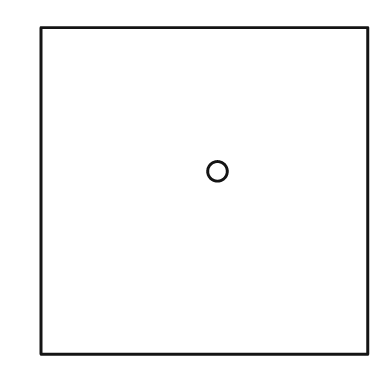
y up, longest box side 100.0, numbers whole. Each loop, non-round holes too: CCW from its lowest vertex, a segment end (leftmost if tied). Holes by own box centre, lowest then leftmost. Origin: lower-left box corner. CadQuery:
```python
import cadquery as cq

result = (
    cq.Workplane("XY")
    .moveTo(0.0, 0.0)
    .lineTo(100.0, 0.0)
    .lineTo(100.0, 100.0)
    .lineTo(0.0, 100.0)
    .close()
    .moveTo(54.0, 56.0)
    .circle(3.0)
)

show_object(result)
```